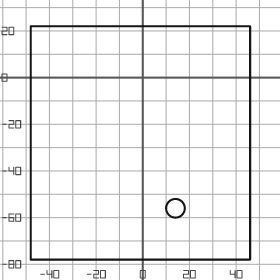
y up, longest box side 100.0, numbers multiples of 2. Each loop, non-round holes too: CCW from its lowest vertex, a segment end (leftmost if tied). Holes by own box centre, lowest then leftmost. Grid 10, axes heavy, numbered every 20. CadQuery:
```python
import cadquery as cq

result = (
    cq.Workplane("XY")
    .moveTo(-48.0, -78.0)
    .lineTo(46.0, -78.0)
    .lineTo(46.0, 22.0)
    .lineTo(-48.0, 22.0)
    .close()
    .moveTo(14.0, -56.0)
    .circle(4.0)
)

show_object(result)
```